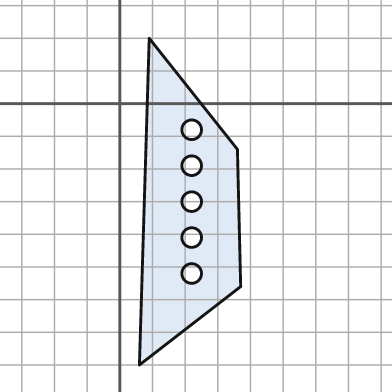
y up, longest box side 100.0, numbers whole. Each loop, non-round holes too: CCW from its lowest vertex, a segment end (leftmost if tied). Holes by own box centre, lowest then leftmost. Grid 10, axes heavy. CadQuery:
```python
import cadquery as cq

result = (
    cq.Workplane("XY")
    .moveTo(6.0, -80.0)
    .lineTo(37.0, -56.0)
    .lineTo(36.0, -14.0)
    .lineTo(9.0, 20.0)
    .close()
    .moveTo(22.0, -52.0)
    .circle(3.0)
    .moveTo(22.0, -41.0)
    .circle(3.0)
    .moveTo(22.0, -30.0)
    .circle(3.0)
    .moveTo(22.0, -19.0)
    .circle(3.0)
    .moveTo(22.0, -8.0)
    .circle(3.0)
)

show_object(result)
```